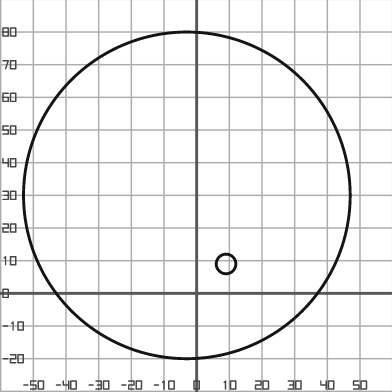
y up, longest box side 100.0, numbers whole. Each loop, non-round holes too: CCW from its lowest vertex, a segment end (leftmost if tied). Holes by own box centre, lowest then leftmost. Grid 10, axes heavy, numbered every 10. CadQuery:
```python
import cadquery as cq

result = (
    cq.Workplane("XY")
    .moveTo(-3.0, 30.0)
    .circle(50.0)
    .moveTo(9.0, 9.0)
    .circle(3.0)
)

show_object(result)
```